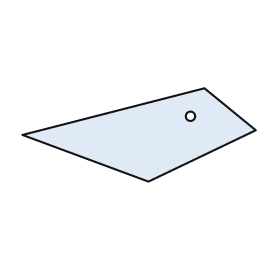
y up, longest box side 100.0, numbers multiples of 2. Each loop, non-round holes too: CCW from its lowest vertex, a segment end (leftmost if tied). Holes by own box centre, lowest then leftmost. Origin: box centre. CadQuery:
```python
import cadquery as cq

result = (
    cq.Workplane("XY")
    .moveTo(4.0, -20.0)
    .lineTo(50.0, 2.0)
    .lineTo(28.0, 20.0)
    .lineTo(-50.0, 0.0)
    .close()
    .moveTo(22.0, 8.0)
    .circle(2.0)
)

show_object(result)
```